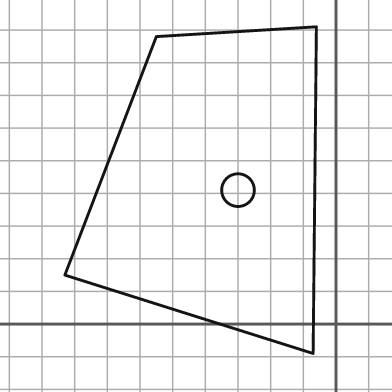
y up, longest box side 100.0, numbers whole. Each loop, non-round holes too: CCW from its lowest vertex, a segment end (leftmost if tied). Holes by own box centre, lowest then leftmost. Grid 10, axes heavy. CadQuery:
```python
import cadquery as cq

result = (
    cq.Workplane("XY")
    .moveTo(-7.0, -9.0)
    .lineTo(-6.0, 91.0)
    .lineTo(-55.0, 88.0)
    .lineTo(-83.0, 15.0)
    .close()
    .moveTo(-30.0, 41.0)
    .circle(5.0)
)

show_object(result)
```